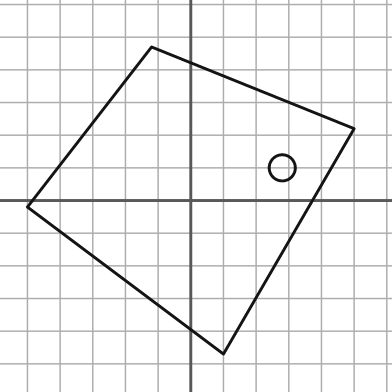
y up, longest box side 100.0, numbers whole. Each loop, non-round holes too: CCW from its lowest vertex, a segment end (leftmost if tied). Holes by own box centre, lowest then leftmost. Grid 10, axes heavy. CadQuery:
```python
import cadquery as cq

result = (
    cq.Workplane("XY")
    .moveTo(10.0, -47.0)
    .lineTo(50.0, 22.0)
    .lineTo(-12.0, 47.0)
    .lineTo(-50.0, -2.0)
    .close()
    .moveTo(28.0, 10.0)
    .circle(4.0)
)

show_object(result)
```